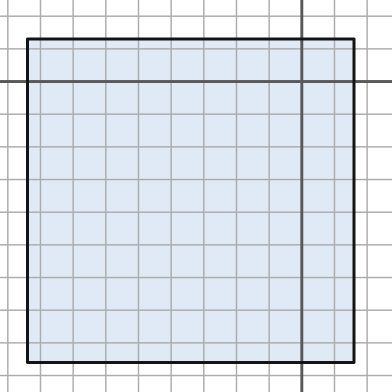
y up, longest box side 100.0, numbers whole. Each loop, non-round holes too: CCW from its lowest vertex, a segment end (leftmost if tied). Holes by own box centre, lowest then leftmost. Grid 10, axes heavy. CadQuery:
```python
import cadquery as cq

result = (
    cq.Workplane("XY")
    .moveTo(-84.0, -86.0)
    .lineTo(16.0, -86.0)
    .lineTo(16.0, 13.0)
    .lineTo(-84.0, 13.0)
    .close()
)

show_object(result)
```